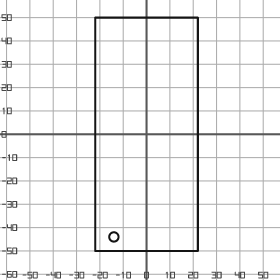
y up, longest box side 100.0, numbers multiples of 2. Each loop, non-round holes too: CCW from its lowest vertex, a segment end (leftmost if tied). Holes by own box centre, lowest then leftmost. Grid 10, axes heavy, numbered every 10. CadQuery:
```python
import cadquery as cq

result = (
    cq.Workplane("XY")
    .moveTo(-22.0, -50.0)
    .lineTo(22.0, -50.0)
    .lineTo(22.0, 50.0)
    .lineTo(-22.0, 50.0)
    .close()
    .moveTo(-14.0, -44.0)
    .circle(2.0)
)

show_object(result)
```